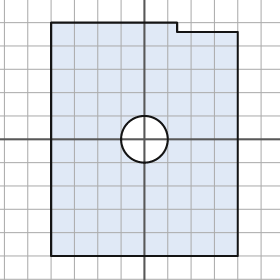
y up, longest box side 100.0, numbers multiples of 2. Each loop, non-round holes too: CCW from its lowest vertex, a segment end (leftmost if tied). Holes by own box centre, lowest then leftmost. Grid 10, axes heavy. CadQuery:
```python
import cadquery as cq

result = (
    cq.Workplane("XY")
    .moveTo(-40.0, -50.0)
    .lineTo(40.0, -50.0)
    .lineTo(40.0, 46.0)
    .lineTo(14.0, 46.0)
    .lineTo(14.0, 50.0)
    .lineTo(-40.0, 50.0)
    .close()
    .moveTo(0.0, 0.0)
    .circle(10.0)
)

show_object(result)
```